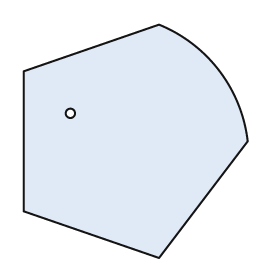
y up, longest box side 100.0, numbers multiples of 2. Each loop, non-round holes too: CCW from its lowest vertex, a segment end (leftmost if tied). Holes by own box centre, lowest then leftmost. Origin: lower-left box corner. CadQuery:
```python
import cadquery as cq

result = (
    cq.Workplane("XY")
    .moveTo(58.0, 0.0)
    .lineTo(96.0, 50.0)
    .threePointArc((84.0, 80.0), (58.0, 100.0))
    .lineTo(0.0, 80.0)
    .lineTo(0.0, 20.0)
    .close()
    .moveTo(20.0, 62.0)
    .circle(2.0)
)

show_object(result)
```